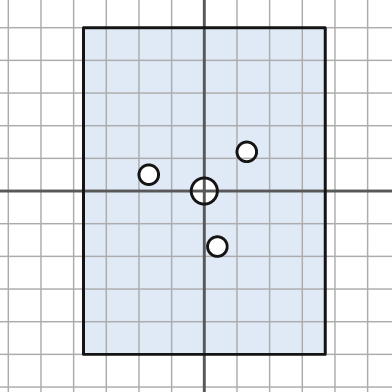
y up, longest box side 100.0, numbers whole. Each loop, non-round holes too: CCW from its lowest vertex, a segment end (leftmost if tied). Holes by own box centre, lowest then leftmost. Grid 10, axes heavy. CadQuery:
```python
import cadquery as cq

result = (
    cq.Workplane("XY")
    .moveTo(-37.0, -50.0)
    .lineTo(37.0, -50.0)
    .lineTo(37.0, 50.0)
    .lineTo(-37.0, 50.0)
    .close()
    .moveTo(4.0, -17.0)
    .circle(3.0)
    .moveTo(0.0, 0.0)
    .circle(4.0)
    .moveTo(-17.0, 5.0)
    .circle(3.0)
    .moveTo(13.0, 12.0)
    .circle(3.0)
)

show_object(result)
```